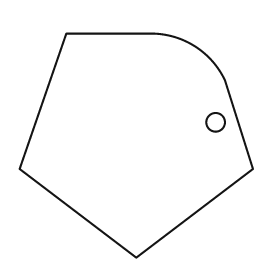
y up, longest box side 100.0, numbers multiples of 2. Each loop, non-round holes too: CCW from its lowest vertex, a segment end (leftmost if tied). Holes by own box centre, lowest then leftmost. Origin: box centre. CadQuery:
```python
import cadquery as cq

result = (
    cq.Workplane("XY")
    .moveTo(0.0, -48.0)
    .lineTo(50.0, -10.0)
    .lineTo(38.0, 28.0)
    .threePointArc((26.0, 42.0), (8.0, 48.0))
    .lineTo(-30.0, 48.0)
    .lineTo(-50.0, -10.0)
    .close()
    .moveTo(34.0, 10.0)
    .circle(4.0)
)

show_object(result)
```